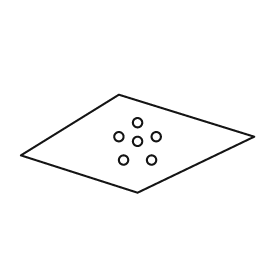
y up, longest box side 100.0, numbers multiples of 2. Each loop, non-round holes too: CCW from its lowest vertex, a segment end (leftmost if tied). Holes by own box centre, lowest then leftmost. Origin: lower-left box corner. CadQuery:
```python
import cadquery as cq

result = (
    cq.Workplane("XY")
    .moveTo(50.0, 0.0)
    .lineTo(100.0, 24.0)
    .lineTo(42.0, 42.0)
    .lineTo(0.0, 16.0)
    .close()
    .moveTo(44.0, 14.0)
    .circle(2.0)
    .moveTo(56.0, 14.0)
    .circle(2.0)
    .moveTo(50.0, 22.0)
    .circle(2.0)
    .moveTo(42.0, 24.0)
    .circle(2.0)
    .moveTo(58.0, 24.0)
    .circle(2.0)
    .moveTo(50.0, 30.0)
    .circle(2.0)
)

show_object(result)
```